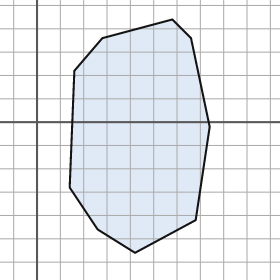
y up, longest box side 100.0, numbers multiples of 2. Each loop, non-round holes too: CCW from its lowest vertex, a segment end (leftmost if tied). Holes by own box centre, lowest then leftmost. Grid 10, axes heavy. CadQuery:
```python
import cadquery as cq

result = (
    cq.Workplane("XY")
    .moveTo(42.0, -56.0)
    .lineTo(68.0, -42.0)
    .lineTo(74.0, -2.0)
    .lineTo(66.0, 36.0)
    .lineTo(58.0, 44.0)
    .lineTo(28.0, 36.0)
    .lineTo(16.0, 22.0)
    .lineTo(14.0, -28.0)
    .lineTo(26.0, -46.0)
    .close()
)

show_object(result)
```